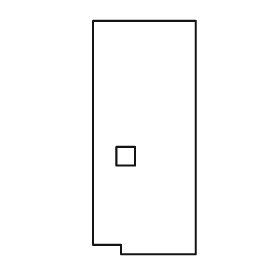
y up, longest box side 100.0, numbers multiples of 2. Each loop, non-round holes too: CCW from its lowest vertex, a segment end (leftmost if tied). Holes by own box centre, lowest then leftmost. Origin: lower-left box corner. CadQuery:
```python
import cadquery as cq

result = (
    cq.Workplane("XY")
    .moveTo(12.0, 0.0)
    .lineTo(44.0, 0.0)
    .lineTo(44.0, 100.0)
    .lineTo(0.0, 100.0)
    .lineTo(0.0, 4.0)
    .lineTo(12.0, 4.0)
    .close()
    .moveTo(10.0, 38.0)
    .lineTo(18.0, 38.0)
    .lineTo(18.0, 46.0)
    .lineTo(10.0, 46.0)
    .close()
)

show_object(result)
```